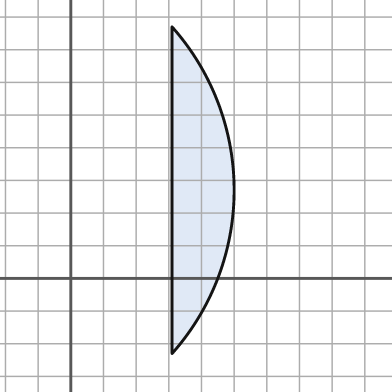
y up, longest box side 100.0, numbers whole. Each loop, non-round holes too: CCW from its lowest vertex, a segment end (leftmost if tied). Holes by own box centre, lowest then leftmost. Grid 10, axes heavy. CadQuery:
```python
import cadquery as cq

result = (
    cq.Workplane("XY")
    .moveTo(31.0, -23.0)
    .threePointArc((50.0, 27.0), (31.0, 77.0))
    .close()
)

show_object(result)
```